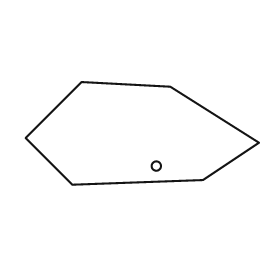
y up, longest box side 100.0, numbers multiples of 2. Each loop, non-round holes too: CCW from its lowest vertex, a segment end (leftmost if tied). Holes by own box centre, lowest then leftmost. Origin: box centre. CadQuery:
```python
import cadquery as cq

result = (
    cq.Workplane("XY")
    .moveTo(-30.0, -22.0)
    .lineTo(26.0, -20.0)
    .lineTo(50.0, -4.0)
    .lineTo(12.0, 20.0)
    .lineTo(-26.0, 22.0)
    .lineTo(-50.0, -2.0)
    .close()
    .moveTo(6.0, -14.0)
    .circle(2.0)
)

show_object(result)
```